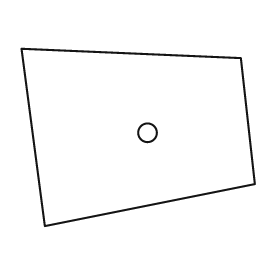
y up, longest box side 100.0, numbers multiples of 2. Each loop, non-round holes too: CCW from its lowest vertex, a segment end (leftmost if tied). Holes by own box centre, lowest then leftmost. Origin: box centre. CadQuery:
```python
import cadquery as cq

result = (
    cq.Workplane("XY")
    .moveTo(-40.0, -38.0)
    .lineTo(50.0, -20.0)
    .lineTo(44.0, 34.0)
    .lineTo(-50.0, 38.0)
    .close()
    .moveTo(4.0, 2.0)
    .circle(4.0)
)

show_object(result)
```